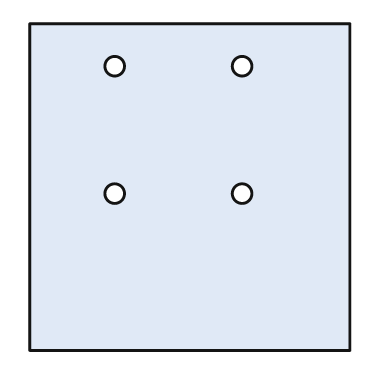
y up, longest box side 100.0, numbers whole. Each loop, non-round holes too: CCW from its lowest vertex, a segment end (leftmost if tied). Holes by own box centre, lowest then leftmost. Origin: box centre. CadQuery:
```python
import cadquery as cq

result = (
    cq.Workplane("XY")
    .moveTo(-49.0, -50.0)
    .lineTo(49.0, -50.0)
    .lineTo(49.0, 50.0)
    .lineTo(-49.0, 50.0)
    .close()
    .moveTo(-23.0, -2.0)
    .circle(3.0)
    .moveTo(16.0, -2.0)
    .circle(3.0)
    .moveTo(-23.0, 37.0)
    .circle(3.0)
    .moveTo(16.0, 37.0)
    .circle(3.0)
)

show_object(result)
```